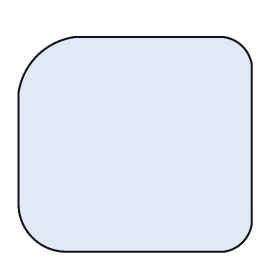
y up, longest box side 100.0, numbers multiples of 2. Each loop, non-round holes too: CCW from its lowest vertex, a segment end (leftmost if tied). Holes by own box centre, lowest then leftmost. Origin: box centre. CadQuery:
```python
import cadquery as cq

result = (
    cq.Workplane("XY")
    .moveTo(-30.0, -46.0)
    .lineTo(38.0, -46.0)
    .threePointArc((46.0, -42.0), (50.0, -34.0))
    .lineTo(50.0, 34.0)
    .threePointArc((46.0, 42.0), (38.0, 46.0))
    .lineTo(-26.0, 46.0)
    .threePointArc((-42.0, 38.0), (-50.0, 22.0))
    .lineTo(-50.0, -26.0)
    .threePointArc((-44.0, -40.0), (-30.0, -46.0))
    .close()
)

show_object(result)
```